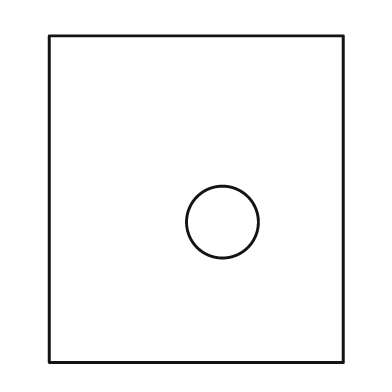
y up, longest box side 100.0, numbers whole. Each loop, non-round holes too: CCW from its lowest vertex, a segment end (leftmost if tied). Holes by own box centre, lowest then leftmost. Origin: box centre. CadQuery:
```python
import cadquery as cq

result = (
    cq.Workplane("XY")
    .moveTo(-45.0, -50.0)
    .lineTo(45.0, -50.0)
    .lineTo(45.0, 50.0)
    .lineTo(-45.0, 50.0)
    .close()
    .moveTo(8.0, -7.0)
    .circle(11.0)
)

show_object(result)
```